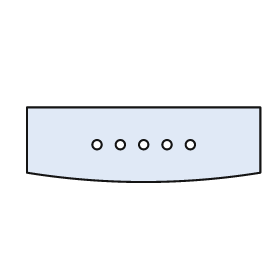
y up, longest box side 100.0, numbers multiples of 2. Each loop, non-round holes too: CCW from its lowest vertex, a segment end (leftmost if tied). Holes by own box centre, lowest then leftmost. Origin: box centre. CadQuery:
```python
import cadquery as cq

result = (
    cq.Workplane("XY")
    .moveTo(-50.0, -12.0)
    .threePointArc((0.0, -16.0), (50.0, -12.0))
    .lineTo(50.0, 16.0)
    .lineTo(-50.0, 16.0)
    .close()
    .moveTo(-20.0, 0.0)
    .circle(2.0)
    .moveTo(-10.0, 0.0)
    .circle(2.0)
    .moveTo(0.0, 0.0)
    .circle(2.0)
    .moveTo(10.0, 0.0)
    .circle(2.0)
    .moveTo(20.0, 0.0)
    .circle(2.0)
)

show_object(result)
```